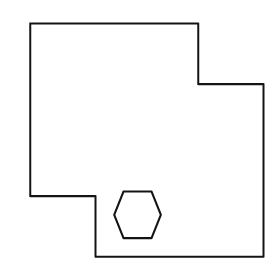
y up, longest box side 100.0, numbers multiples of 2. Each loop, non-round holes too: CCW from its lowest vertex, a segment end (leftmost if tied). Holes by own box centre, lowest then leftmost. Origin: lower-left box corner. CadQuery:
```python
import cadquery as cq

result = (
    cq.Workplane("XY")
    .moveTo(28.0, 0.0)
    .lineTo(100.0, 0.0)
    .lineTo(100.0, 74.0)
    .lineTo(72.0, 74.0)
    .lineTo(72.0, 100.0)
    .lineTo(0.0, 100.0)
    .lineTo(0.0, 26.0)
    .lineTo(28.0, 26.0)
    .close()
    .moveTo(40.0, 8.0)
    .lineTo(52.0, 8.0)
    .lineTo(56.0, 18.0)
    .lineTo(52.0, 28.0)
    .lineTo(40.0, 28.0)
    .lineTo(36.0, 18.0)
    .close()
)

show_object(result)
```